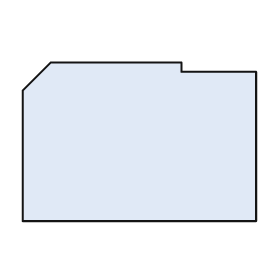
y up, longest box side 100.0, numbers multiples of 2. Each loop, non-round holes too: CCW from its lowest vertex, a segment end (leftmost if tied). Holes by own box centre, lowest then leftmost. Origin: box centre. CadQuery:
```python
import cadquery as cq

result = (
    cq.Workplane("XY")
    .moveTo(-50.0, -34.0)
    .lineTo(50.0, -34.0)
    .lineTo(50.0, 30.0)
    .lineTo(18.0, 30.0)
    .lineTo(18.0, 34.0)
    .lineTo(-38.0, 34.0)
    .lineTo(-50.0, 22.0)
    .close()
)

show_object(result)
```